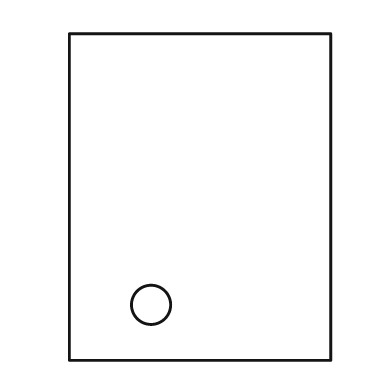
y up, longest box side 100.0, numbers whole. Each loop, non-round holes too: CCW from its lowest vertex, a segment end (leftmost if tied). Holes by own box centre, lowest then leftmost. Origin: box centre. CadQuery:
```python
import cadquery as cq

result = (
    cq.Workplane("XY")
    .moveTo(-40.0, -50.0)
    .lineTo(40.0, -50.0)
    .lineTo(40.0, 50.0)
    .lineTo(-40.0, 50.0)
    .close()
    .moveTo(-15.0, -33.0)
    .circle(6.0)
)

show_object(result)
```